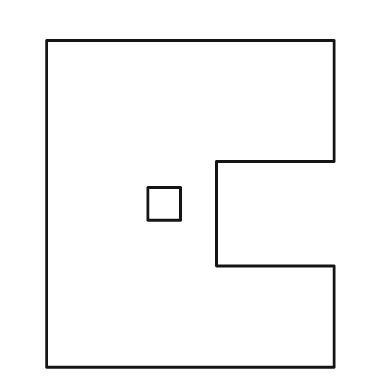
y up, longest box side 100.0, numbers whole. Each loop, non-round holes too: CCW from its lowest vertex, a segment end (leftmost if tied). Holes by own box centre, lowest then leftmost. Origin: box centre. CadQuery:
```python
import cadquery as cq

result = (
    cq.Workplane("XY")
    .moveTo(-44.0, -50.0)
    .lineTo(44.0, -50.0)
    .lineTo(44.0, -19.0)
    .lineTo(8.0, -19.0)
    .lineTo(8.0, 13.0)
    .lineTo(44.0, 13.0)
    .lineTo(44.0, 50.0)
    .lineTo(-44.0, 50.0)
    .close()
    .moveTo(-13.0, -5.0)
    .lineTo(-3.0, -5.0)
    .lineTo(-3.0, 5.0)
    .lineTo(-13.0, 5.0)
    .close()
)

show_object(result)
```